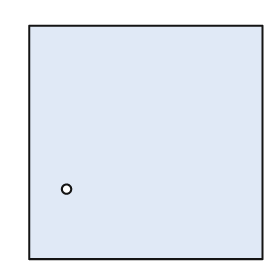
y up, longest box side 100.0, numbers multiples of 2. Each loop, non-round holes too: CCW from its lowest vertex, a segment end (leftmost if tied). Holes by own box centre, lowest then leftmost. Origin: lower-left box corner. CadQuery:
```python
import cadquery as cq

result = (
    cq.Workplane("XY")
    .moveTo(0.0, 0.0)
    .lineTo(100.0, 0.0)
    .lineTo(100.0, 100.0)
    .lineTo(0.0, 100.0)
    .close()
    .moveTo(16.0, 30.0)
    .circle(2.0)
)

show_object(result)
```